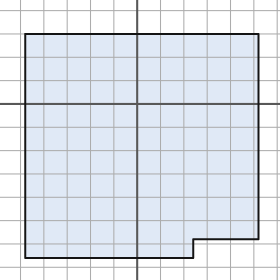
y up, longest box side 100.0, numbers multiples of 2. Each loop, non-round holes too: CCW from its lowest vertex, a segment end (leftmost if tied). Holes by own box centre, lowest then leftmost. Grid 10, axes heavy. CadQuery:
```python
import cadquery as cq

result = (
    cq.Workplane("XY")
    .moveTo(-48.0, -66.0)
    .lineTo(24.0, -66.0)
    .lineTo(24.0, -58.0)
    .lineTo(52.0, -58.0)
    .lineTo(52.0, 30.0)
    .lineTo(-48.0, 30.0)
    .close()
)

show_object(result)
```